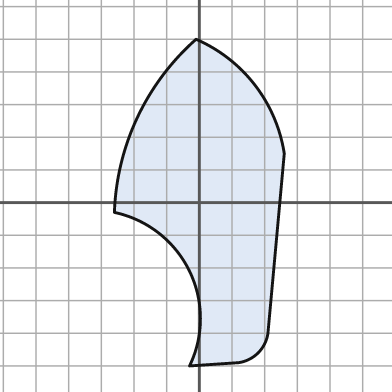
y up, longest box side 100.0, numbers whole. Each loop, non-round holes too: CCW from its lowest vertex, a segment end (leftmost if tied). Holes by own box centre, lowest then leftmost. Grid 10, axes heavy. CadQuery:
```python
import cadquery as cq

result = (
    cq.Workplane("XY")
    .moveTo(-3.0, -50.0)
    .lineTo(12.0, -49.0)
    .threePointArc((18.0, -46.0), (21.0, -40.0))
    .lineTo(26.0, 15.0)
    .threePointArc((17.0, 36.0), (-1.0, 50.0))
    .threePointArc((-19.0, 26.0), (-26.0, -3.0))
    .threePointArc((-3.0, -21.0), (-3.0, -50.0))
    .close()
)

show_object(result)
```